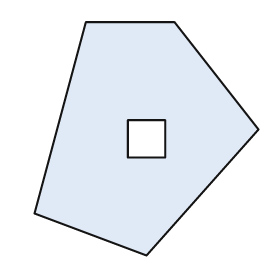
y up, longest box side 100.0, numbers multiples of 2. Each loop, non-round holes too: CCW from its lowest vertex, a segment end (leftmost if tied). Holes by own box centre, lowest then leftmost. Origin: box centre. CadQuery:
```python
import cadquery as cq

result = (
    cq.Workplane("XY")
    .moveTo(0.0, -50.0)
    .lineTo(48.0, 4.0)
    .lineTo(12.0, 50.0)
    .lineTo(-26.0, 50.0)
    .lineTo(-48.0, -32.0)
    .close()
    .moveTo(-8.0, -8.0)
    .lineTo(8.0, -8.0)
    .lineTo(8.0, 8.0)
    .lineTo(-8.0, 8.0)
    .close()
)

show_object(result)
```